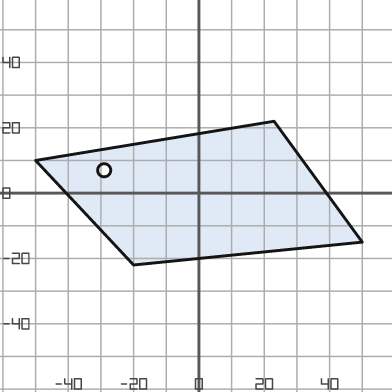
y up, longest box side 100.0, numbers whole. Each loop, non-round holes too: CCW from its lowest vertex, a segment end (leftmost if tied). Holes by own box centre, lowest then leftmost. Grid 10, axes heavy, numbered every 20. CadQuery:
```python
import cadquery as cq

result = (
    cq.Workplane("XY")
    .moveTo(-20.0, -22.0)
    .lineTo(50.0, -15.0)
    .lineTo(23.0, 22.0)
    .lineTo(-50.0, 10.0)
    .close()
    .moveTo(-29.0, 7.0)
    .circle(2.0)
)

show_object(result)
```